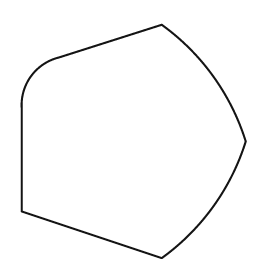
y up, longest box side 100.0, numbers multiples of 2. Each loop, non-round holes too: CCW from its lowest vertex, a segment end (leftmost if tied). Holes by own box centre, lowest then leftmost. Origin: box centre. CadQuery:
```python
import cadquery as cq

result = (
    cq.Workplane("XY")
    .moveTo(12.0, -50.0)
    .threePointArc((34.0, -28.0), (48.0, 0.0))
    .threePointArc((34.0, 28.0), (12.0, 50.0))
    .lineTo(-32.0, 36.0)
    .threePointArc((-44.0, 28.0), (-48.0, 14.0))
    .lineTo(-48.0, -30.0)
    .close()
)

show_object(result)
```